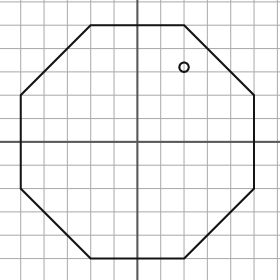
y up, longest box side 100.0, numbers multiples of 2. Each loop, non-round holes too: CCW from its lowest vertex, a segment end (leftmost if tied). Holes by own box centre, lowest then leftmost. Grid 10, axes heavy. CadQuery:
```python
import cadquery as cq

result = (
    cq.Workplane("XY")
    .moveTo(-20.0, -50.0)
    .lineTo(20.0, -50.0)
    .lineTo(50.0, -20.0)
    .lineTo(50.0, 20.0)
    .lineTo(20.0, 50.0)
    .lineTo(-20.0, 50.0)
    .lineTo(-50.0, 20.0)
    .lineTo(-50.0, -20.0)
    .close()
    .moveTo(20.0, 32.0)
    .circle(2.0)
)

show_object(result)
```